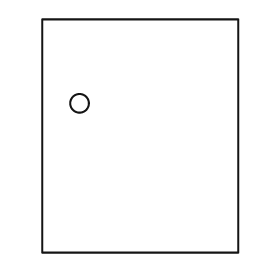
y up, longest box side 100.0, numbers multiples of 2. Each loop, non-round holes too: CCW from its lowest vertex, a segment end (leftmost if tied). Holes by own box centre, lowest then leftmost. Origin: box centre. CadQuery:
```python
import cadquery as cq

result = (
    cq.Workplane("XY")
    .moveTo(-42.0, -50.0)
    .lineTo(42.0, -50.0)
    .lineTo(42.0, 50.0)
    .lineTo(-42.0, 50.0)
    .close()
    .moveTo(-26.0, 14.0)
    .circle(4.0)
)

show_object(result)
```